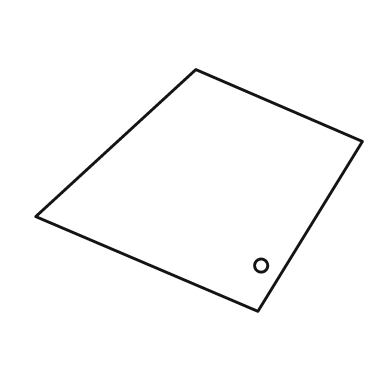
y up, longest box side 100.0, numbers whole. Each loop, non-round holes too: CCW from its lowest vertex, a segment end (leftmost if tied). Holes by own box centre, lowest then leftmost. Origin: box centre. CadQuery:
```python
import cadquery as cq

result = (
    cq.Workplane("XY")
    .moveTo(18.0, -37.0)
    .lineTo(50.0, 15.0)
    .lineTo(-1.0, 37.0)
    .lineTo(-50.0, -8.0)
    .close()
    .moveTo(19.0, -23.0)
    .circle(2.0)
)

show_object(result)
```